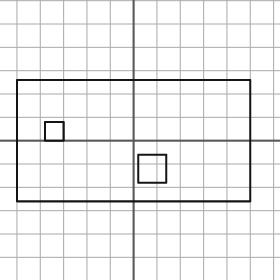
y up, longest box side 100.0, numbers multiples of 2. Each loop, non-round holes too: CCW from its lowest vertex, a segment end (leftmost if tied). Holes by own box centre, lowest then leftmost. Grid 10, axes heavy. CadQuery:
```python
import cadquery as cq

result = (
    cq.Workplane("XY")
    .moveTo(-50.0, -26.0)
    .lineTo(50.0, -26.0)
    .lineTo(50.0, 26.0)
    .lineTo(-50.0, 26.0)
    .close()
    .moveTo(2.0, -18.0)
    .lineTo(14.0, -18.0)
    .lineTo(14.0, -6.0)
    .lineTo(2.0, -6.0)
    .close()
    .moveTo(-38.0, 0.0)
    .lineTo(-30.0, 0.0)
    .lineTo(-30.0, 8.0)
    .lineTo(-38.0, 8.0)
    .close()
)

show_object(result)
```